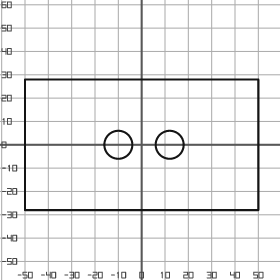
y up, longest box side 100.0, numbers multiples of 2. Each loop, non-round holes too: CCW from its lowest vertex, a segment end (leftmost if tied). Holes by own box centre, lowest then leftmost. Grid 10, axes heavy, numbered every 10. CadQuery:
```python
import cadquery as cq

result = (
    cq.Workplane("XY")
    .moveTo(-50.0, -28.0)
    .lineTo(50.0, -28.0)
    .lineTo(50.0, 28.0)
    .lineTo(-50.0, 28.0)
    .close()
    .moveTo(-10.0, 0.0)
    .circle(6.0)
    .moveTo(12.0, 0.0)
    .circle(6.0)
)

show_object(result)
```